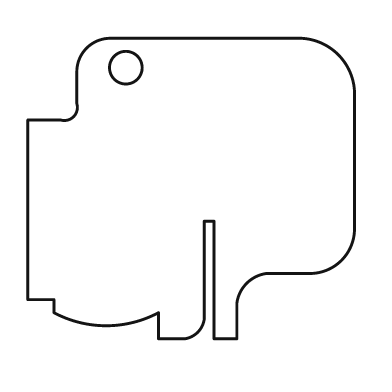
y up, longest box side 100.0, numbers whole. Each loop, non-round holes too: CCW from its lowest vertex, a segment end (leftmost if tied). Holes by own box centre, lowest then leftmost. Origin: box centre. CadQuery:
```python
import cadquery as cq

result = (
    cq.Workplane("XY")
    .moveTo(-10.0, -46.0)
    .lineTo(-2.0, -46.0)
    .threePointArc((2.0, -44.0), (4.0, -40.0))
    .lineTo(4.0, -10.0)
    .lineTo(7.0, -10.0)
    .lineTo(7.0, -46.0)
    .lineTo(14.0, -46.0)
    .lineTo(14.0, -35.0)
    .threePointArc((17.0, -29.0), (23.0, -26.0))
    .lineTo(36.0, -26.0)
    .threePointArc((46.0, -22.0), (50.0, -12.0))
    .lineTo(50.0, 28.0)
    .threePointArc((45.0, 41.0), (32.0, 46.0))
    .lineTo(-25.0, 46.0)
    .threePointArc((-32.0, 43.0), (-35.0, 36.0))
    .lineTo(-35.0, 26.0)
    .threePointArc((-36.0, 22.0), (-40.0, 21.0))
    .lineTo(-50.0, 21.0)
    .lineTo(-50.0, -34.0)
    .lineTo(-42.0, -34.0)
    .lineTo(-42.0, -38.0)
    .threePointArc((-26.0, -42.0), (-10.0, -38.0))
    .close()
    .moveTo(-20.0, 37.0)
    .circle(5.0)
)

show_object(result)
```